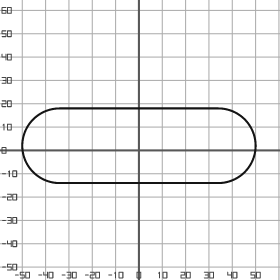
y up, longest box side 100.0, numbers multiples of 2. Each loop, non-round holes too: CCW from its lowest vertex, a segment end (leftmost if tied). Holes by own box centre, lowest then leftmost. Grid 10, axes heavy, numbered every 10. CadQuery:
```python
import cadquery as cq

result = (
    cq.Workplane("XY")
    .moveTo(-34.0, -14.0)
    .lineTo(34.0, -14.0)
    .threePointArc((50.0, 2.0), (34.0, 18.0))
    .lineTo(-34.0, 18.0)
    .threePointArc((-50.0, 2.0), (-34.0, -14.0))
    .close()
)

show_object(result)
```